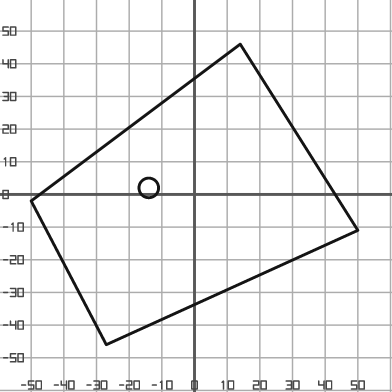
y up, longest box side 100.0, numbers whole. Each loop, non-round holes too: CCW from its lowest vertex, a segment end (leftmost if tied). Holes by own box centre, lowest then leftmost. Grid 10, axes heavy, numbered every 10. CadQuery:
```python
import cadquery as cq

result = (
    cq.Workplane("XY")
    .moveTo(-27.0, -46.0)
    .lineTo(50.0, -11.0)
    .lineTo(14.0, 46.0)
    .lineTo(-50.0, -2.0)
    .close()
    .moveTo(-14.0, 2.0)
    .circle(3.0)
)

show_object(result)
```